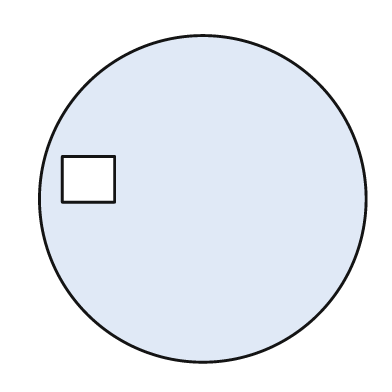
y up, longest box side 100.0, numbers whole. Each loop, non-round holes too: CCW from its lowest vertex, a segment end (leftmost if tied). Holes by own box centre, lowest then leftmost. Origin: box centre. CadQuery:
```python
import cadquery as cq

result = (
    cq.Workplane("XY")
    .moveTo(0.0, 0.0)
    .circle(50.0)
    .moveTo(-43.0, -1.0)
    .lineTo(-27.0, -1.0)
    .lineTo(-27.0, 13.0)
    .lineTo(-43.0, 13.0)
    .close()
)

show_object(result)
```